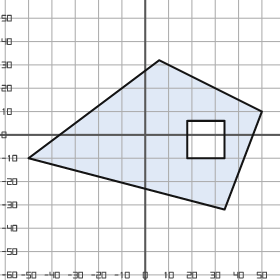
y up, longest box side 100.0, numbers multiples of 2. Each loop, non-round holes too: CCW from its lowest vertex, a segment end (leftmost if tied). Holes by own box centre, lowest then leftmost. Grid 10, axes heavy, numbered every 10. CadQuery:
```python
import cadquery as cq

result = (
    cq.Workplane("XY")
    .moveTo(34.0, -32.0)
    .lineTo(50.0, 10.0)
    .lineTo(6.0, 32.0)
    .lineTo(-50.0, -10.0)
    .close()
    .moveTo(18.0, -10.0)
    .lineTo(34.0, -10.0)
    .lineTo(34.0, 6.0)
    .lineTo(18.0, 6.0)
    .close()
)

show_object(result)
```